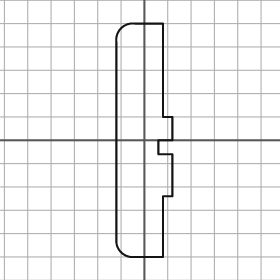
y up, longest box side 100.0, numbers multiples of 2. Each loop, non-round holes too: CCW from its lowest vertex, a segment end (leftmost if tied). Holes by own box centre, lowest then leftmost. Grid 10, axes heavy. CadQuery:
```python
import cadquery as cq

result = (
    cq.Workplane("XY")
    .moveTo(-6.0, -50.0)
    .lineTo(8.0, -50.0)
    .lineTo(8.0, -24.0)
    .lineTo(12.0, -24.0)
    .lineTo(12.0, -6.0)
    .lineTo(6.0, -6.0)
    .lineTo(6.0, 0.0)
    .lineTo(12.0, 0.0)
    .lineTo(12.0, 10.0)
    .lineTo(8.0, 10.0)
    .lineTo(8.0, 50.0)
    .lineTo(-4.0, 50.0)
    .threePointArc((-10.0, 48.0), (-12.0, 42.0))
    .lineTo(-12.0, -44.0)
    .threePointArc((-10.0, -48.0), (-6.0, -50.0))
    .close()
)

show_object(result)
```